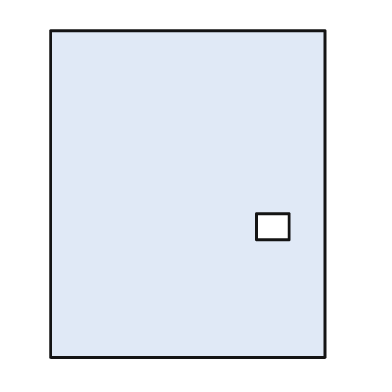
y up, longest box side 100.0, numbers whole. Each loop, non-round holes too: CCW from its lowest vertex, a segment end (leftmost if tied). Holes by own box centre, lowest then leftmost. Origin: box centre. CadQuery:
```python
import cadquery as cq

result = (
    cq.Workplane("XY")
    .moveTo(-42.0, -50.0)
    .lineTo(42.0, -50.0)
    .lineTo(42.0, 50.0)
    .lineTo(-42.0, 50.0)
    .close()
    .moveTo(21.0, -14.0)
    .lineTo(31.0, -14.0)
    .lineTo(31.0, -6.0)
    .lineTo(21.0, -6.0)
    .close()
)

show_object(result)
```